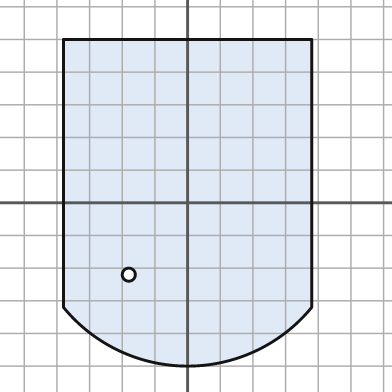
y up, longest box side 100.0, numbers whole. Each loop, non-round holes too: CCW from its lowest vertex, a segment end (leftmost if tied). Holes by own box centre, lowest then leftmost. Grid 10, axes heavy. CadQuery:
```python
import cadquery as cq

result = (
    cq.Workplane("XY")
    .moveTo(-38.0, -32.0)
    .threePointArc((0.0, -50.0), (38.0, -32.0))
    .lineTo(38.0, 50.0)
    .lineTo(-38.0, 50.0)
    .close()
    .moveTo(-18.0, -22.0)
    .circle(2.0)
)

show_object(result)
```